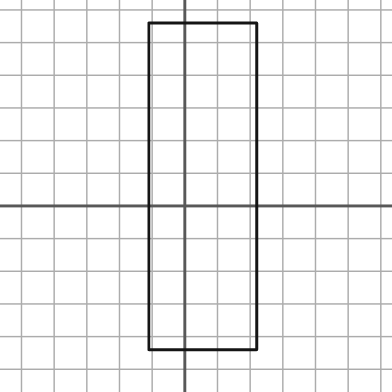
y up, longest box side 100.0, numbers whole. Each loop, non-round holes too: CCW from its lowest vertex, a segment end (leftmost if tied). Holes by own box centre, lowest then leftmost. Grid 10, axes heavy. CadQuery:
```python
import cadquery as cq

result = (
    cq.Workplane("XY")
    .moveTo(-11.0, -44.0)
    .lineTo(22.0, -44.0)
    .lineTo(22.0, 56.0)
    .lineTo(-11.0, 56.0)
    .close()
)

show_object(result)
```